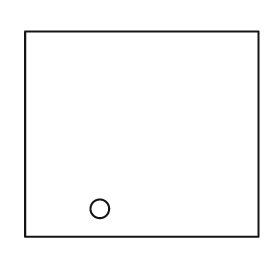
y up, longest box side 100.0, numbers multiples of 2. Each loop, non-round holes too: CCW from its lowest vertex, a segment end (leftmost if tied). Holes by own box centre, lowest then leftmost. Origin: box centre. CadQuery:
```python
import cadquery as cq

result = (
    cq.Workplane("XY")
    .moveTo(-50.0, -44.0)
    .lineTo(50.0, -44.0)
    .lineTo(50.0, 44.0)
    .lineTo(-50.0, 44.0)
    .close()
    .moveTo(-18.0, -32.0)
    .circle(4.0)
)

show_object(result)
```